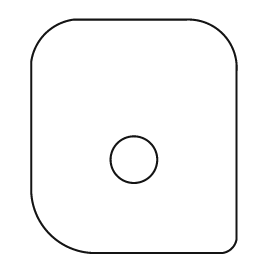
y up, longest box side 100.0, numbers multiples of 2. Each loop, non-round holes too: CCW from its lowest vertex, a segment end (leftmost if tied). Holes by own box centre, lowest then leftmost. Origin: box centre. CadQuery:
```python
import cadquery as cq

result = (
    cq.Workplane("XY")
    .moveTo(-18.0, -50.0)
    .lineTo(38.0, -50.0)
    .threePointArc((42.0, -48.0), (44.0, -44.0))
    .lineTo(44.0, 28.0)
    .threePointArc((38.0, 44.0), (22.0, 50.0))
    .lineTo(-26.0, 50.0)
    .threePointArc((-38.0, 44.0), (-44.0, 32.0))
    .lineTo(-44.0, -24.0)
    .threePointArc((-36.0, -42.0), (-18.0, -50.0))
    .close()
    .moveTo(0.0, -10.0)
    .circle(10.0)
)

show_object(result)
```